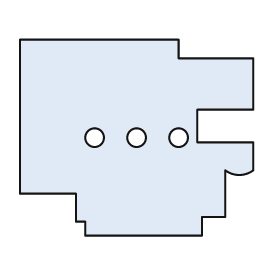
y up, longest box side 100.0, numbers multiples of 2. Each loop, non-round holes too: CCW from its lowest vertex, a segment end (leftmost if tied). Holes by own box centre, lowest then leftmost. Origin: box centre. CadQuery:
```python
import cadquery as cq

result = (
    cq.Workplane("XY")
    .moveTo(-22.0, -42.0)
    .lineTo(28.0, -42.0)
    .lineTo(28.0, -34.0)
    .lineTo(38.0, -34.0)
    .lineTo(38.0, -14.0)
    .threePointArc((44.0, -16.0), (50.0, -14.0))
    .lineTo(50.0, -2.0)
    .lineTo(26.0, -2.0)
    .lineTo(26.0, 12.0)
    .lineTo(50.0, 12.0)
    .lineTo(50.0, 34.0)
    .lineTo(18.0, 34.0)
    .lineTo(18.0, 42.0)
    .lineTo(-50.0, 42.0)
    .lineTo(-50.0, -24.0)
    .lineTo(-26.0, -24.0)
    .lineTo(-26.0, -36.0)
    .lineTo(-22.0, -36.0)
    .close()
    .moveTo(-18.0, 0.0)
    .circle(4.0)
    .moveTo(0.0, 0.0)
    .circle(4.0)
    .moveTo(18.0, 0.0)
    .circle(4.0)
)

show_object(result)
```